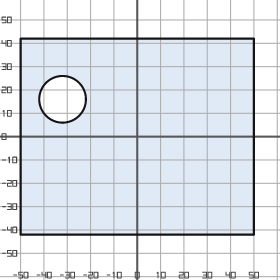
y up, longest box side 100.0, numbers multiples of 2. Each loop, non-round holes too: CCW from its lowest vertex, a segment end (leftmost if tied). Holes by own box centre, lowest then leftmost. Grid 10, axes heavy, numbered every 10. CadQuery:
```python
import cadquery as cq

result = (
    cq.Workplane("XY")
    .moveTo(-50.0, -42.0)
    .lineTo(50.0, -42.0)
    .lineTo(50.0, 42.0)
    .lineTo(-50.0, 42.0)
    .close()
    .moveTo(-32.0, 16.0)
    .circle(10.0)
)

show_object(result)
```